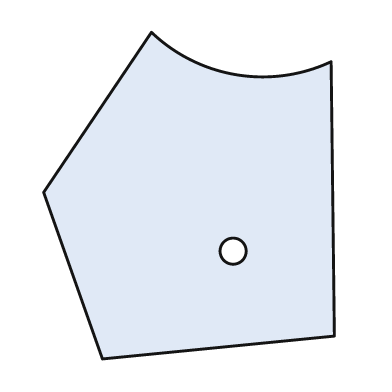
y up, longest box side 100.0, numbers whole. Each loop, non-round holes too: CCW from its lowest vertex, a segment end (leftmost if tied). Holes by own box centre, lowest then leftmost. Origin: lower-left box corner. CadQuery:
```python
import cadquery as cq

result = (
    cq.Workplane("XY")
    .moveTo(18.0, 0.0)
    .lineTo(89.0, 7.0)
    .lineTo(88.0, 91.0)
    .threePointArc((59.0, 87.0), (33.0, 100.0))
    .lineTo(0.0, 51.0)
    .close()
    .moveTo(58.0, 33.0)
    .circle(4.0)
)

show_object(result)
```